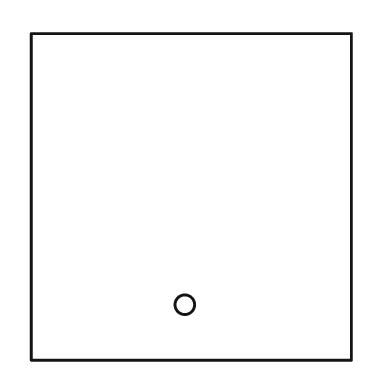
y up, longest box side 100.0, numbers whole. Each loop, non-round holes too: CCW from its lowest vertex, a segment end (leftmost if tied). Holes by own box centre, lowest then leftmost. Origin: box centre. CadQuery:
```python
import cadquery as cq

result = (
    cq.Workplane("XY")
    .moveTo(-49.0, -50.0)
    .lineTo(49.0, -50.0)
    .lineTo(49.0, 50.0)
    .lineTo(-49.0, 50.0)
    .close()
    .moveTo(-2.0, -33.0)
    .circle(3.0)
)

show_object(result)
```